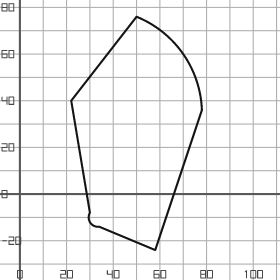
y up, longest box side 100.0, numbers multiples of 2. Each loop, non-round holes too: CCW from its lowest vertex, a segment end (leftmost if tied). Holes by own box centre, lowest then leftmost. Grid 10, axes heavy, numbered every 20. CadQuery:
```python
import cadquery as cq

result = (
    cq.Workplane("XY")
    .moveTo(58.0, -24.0)
    .lineTo(78.0, 36.0)
    .threePointArc((70.0, 60.0), (50.0, 76.0))
    .lineTo(22.0, 40.0)
    .lineTo(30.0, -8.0)
    .threePointArc((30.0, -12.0), (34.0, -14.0))
    .close()
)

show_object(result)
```